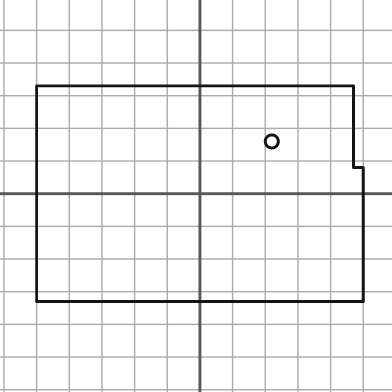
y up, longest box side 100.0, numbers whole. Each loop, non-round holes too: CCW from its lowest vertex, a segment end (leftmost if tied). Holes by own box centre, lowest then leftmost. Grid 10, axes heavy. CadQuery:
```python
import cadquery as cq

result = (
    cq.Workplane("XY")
    .moveTo(-50.0, -33.0)
    .lineTo(50.0, -33.0)
    .lineTo(50.0, 8.0)
    .lineTo(47.0, 8.0)
    .lineTo(47.0, 33.0)
    .lineTo(-50.0, 33.0)
    .close()
    .moveTo(22.0, 16.0)
    .circle(2.0)
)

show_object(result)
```